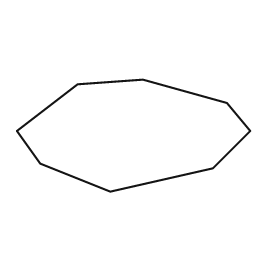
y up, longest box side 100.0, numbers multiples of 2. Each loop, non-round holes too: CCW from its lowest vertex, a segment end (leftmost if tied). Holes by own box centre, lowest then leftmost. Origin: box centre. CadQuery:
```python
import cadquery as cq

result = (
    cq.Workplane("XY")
    .moveTo(-10.0, -24.0)
    .lineTo(34.0, -14.0)
    .lineTo(50.0, 2.0)
    .lineTo(40.0, 14.0)
    .lineTo(4.0, 24.0)
    .lineTo(-24.0, 22.0)
    .lineTo(-50.0, 2.0)
    .lineTo(-40.0, -12.0)
    .close()
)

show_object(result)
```